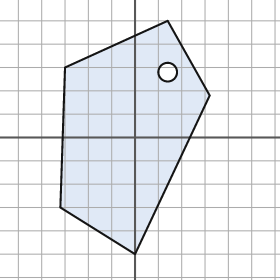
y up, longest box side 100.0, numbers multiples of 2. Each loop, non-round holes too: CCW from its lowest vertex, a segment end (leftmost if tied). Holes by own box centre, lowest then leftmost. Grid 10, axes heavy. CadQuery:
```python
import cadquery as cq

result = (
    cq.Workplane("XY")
    .moveTo(0.0, -50.0)
    .lineTo(32.0, 18.0)
    .lineTo(14.0, 50.0)
    .lineTo(-30.0, 30.0)
    .lineTo(-32.0, -30.0)
    .close()
    .moveTo(14.0, 28.0)
    .circle(4.0)
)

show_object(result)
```